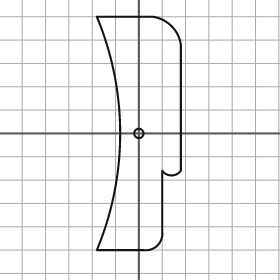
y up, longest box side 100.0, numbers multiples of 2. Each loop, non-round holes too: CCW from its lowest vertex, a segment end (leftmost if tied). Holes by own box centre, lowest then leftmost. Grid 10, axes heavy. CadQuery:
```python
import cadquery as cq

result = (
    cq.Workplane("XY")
    .moveTo(-18.0, -50.0)
    .lineTo(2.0, -50.0)
    .threePointArc((8.0, -48.0), (10.0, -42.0))
    .lineTo(10.0, -16.0)
    .threePointArc((14.0, -18.0), (18.0, -16.0))
    .lineTo(18.0, 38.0)
    .threePointArc((14.0, 46.0), (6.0, 50.0))
    .lineTo(-18.0, 50.0)
    .threePointArc((-8.0, 0.0), (-18.0, -50.0))
    .close()
    .moveTo(0.0, 0.0)
    .circle(2.0)
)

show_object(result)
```